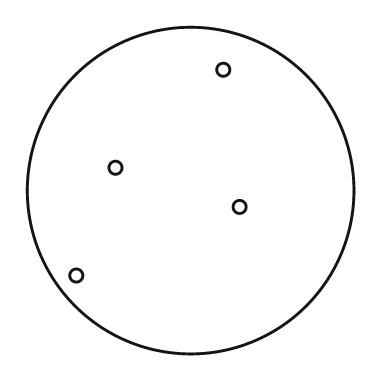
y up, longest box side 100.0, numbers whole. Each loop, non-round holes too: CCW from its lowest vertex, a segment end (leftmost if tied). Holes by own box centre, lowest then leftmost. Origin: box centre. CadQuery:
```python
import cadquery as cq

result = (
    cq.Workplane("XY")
    .moveTo(0.0, 0.0)
    .circle(50.0)
    .moveTo(-35.0, -26.0)
    .circle(2.0)
    .moveTo(15.0, -5.0)
    .circle(2.0)
    .moveTo(-23.0, 7.0)
    .circle(2.0)
    .moveTo(10.0, 37.0)
    .circle(2.0)
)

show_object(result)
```